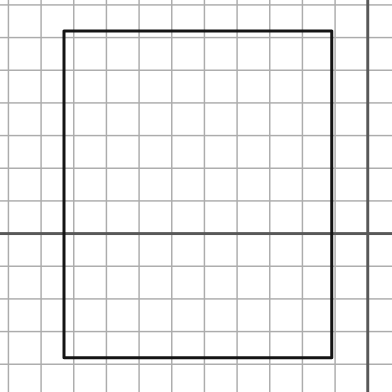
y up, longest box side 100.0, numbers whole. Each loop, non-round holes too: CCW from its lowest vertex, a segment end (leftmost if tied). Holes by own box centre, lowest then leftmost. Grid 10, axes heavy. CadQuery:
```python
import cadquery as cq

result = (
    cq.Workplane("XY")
    .moveTo(-93.0, -38.0)
    .lineTo(-11.0, -38.0)
    .lineTo(-11.0, 62.0)
    .lineTo(-93.0, 62.0)
    .close()
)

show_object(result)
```